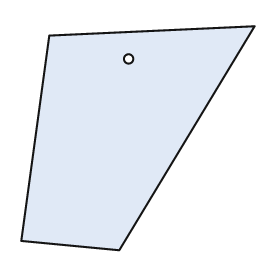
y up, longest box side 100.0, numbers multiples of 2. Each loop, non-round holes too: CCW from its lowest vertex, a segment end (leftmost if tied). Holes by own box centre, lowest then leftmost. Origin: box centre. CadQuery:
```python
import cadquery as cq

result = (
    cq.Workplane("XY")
    .moveTo(-8.0, -48.0)
    .lineTo(50.0, 48.0)
    .lineTo(-38.0, 44.0)
    .lineTo(-50.0, -44.0)
    .close()
    .moveTo(-4.0, 34.0)
    .circle(2.0)
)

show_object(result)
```